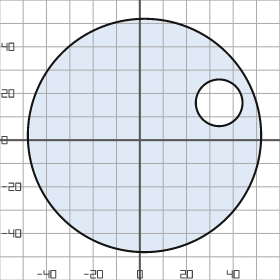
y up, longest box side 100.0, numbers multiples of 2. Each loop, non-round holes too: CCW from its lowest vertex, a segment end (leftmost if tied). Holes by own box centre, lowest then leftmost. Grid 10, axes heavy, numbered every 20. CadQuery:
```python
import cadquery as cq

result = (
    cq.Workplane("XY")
    .moveTo(2.0, 2.0)
    .circle(50.0)
    .moveTo(34.0, 16.0)
    .circle(10.0)
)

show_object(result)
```